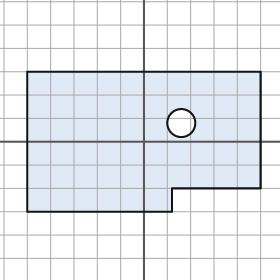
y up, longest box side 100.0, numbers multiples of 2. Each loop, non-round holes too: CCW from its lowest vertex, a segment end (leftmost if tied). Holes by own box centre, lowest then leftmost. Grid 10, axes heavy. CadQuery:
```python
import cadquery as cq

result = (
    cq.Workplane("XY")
    .moveTo(-50.0, -30.0)
    .lineTo(12.0, -30.0)
    .lineTo(12.0, -20.0)
    .lineTo(50.0, -20.0)
    .lineTo(50.0, 30.0)
    .lineTo(-50.0, 30.0)
    .close()
    .moveTo(16.0, 8.0)
    .circle(6.0)
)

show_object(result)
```